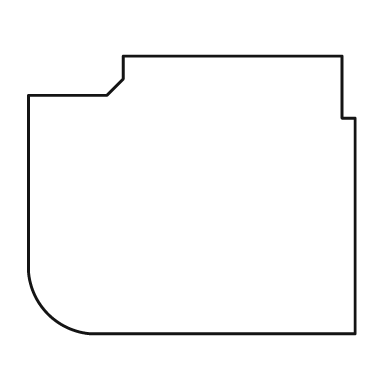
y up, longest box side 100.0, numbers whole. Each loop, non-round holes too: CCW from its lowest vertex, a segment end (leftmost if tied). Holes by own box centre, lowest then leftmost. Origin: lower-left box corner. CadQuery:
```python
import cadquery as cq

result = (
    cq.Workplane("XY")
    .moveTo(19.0, 0.0)
    .lineTo(100.0, 0.0)
    .lineTo(100.0, 66.0)
    .lineTo(96.0, 66.0)
    .lineTo(96.0, 85.0)
    .lineTo(29.0, 85.0)
    .lineTo(29.0, 78.0)
    .lineTo(24.0, 73.0)
    .lineTo(0.0, 73.0)
    .lineTo(0.0, 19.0)
    .threePointArc((6.0, 6.0), (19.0, 0.0))
    .close()
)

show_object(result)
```